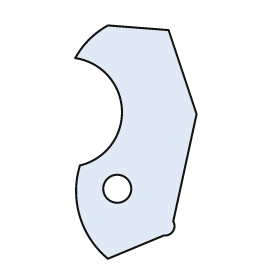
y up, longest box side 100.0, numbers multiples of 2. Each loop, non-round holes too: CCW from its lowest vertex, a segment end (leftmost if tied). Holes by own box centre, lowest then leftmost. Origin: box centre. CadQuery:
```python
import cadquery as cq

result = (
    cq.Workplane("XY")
    .moveTo(-12.0, -50.0)
    .lineTo(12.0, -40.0)
    .threePointArc((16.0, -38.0), (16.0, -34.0))
    .lineTo(26.0, 12.0)
    .lineTo(14.0, 48.0)
    .lineTo(-12.0, 50.0)
    .threePointArc((-20.0, 44.0), (-26.0, 36.0))
    .threePointArc((-6.0, 14.0), (-24.0, -10.0))
    .threePointArc((-24.0, -32.0), (-12.0, -50.0))
    .close()
    .moveTo(-8.0, -20.0)
    .circle(6.0)
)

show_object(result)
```